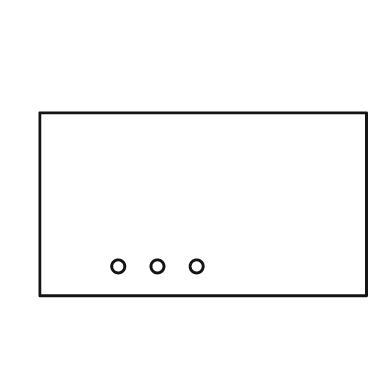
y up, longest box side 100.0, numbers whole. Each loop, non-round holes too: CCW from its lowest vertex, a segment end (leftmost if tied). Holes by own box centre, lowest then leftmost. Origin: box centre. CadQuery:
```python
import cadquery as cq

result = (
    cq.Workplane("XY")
    .moveTo(-50.0, -28.0)
    .lineTo(50.0, -28.0)
    .lineTo(50.0, 28.0)
    .lineTo(-50.0, 28.0)
    .close()
    .moveTo(-26.0, -19.0)
    .circle(2.0)
    .moveTo(-14.0, -19.0)
    .circle(2.0)
    .moveTo(-2.0, -19.0)
    .circle(2.0)
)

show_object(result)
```